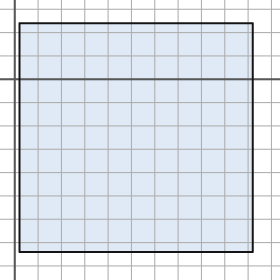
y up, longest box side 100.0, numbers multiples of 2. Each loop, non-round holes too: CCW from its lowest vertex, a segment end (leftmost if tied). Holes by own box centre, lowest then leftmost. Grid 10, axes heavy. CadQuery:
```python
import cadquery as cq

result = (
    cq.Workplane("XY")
    .moveTo(2.0, -74.0)
    .lineTo(102.0, -74.0)
    .lineTo(102.0, 24.0)
    .lineTo(2.0, 24.0)
    .close()
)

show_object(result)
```